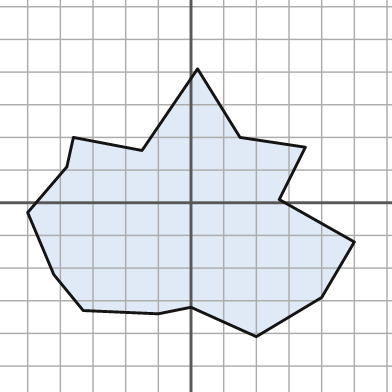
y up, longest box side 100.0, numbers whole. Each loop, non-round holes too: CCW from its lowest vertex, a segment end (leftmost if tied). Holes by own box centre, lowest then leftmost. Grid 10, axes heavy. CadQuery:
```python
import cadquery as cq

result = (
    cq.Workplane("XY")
    .moveTo(20.0, -41.0)
    .lineTo(40.0, -29.0)
    .lineTo(50.0, -12.0)
    .lineTo(27.0, 1.0)
    .lineTo(35.0, 17.0)
    .lineTo(15.0, 20.0)
    .lineTo(2.0, 41.0)
    .lineTo(-15.0, 16.0)
    .lineTo(-36.0, 20.0)
    .lineTo(-38.0, 11.0)
    .lineTo(-50.0, -3.0)
    .lineTo(-42.0, -22.0)
    .lineTo(-33.0, -33.0)
    .lineTo(-10.0, -34.0)
    .lineTo(0.0, -32.0)
    .close()
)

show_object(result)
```